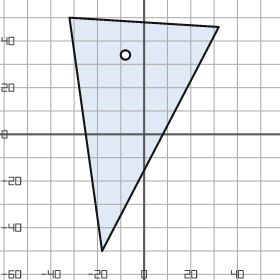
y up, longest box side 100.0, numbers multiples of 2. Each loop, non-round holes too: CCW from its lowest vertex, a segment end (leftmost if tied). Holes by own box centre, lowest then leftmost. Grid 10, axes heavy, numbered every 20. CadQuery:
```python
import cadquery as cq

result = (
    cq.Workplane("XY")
    .moveTo(-18.0, -50.0)
    .lineTo(32.0, 46.0)
    .lineTo(-32.0, 50.0)
    .close()
    .moveTo(-8.0, 34.0)
    .circle(2.0)
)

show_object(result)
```